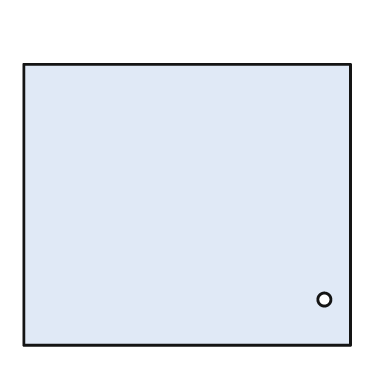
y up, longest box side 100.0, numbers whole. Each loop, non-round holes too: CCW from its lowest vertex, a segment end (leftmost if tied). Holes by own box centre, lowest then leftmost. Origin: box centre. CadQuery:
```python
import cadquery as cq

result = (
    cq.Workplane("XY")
    .moveTo(-50.0, -43.0)
    .lineTo(50.0, -43.0)
    .lineTo(50.0, 43.0)
    .lineTo(-50.0, 43.0)
    .close()
    .moveTo(42.0, -29.0)
    .circle(2.0)
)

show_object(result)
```